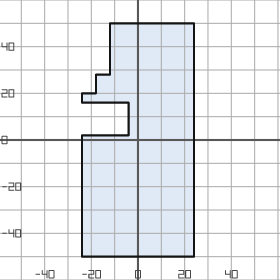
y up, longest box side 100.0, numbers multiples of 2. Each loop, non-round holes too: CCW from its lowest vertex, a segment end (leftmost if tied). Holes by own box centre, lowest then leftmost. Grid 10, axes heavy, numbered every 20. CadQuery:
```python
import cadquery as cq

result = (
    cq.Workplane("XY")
    .moveTo(-24.0, -50.0)
    .lineTo(24.0, -50.0)
    .lineTo(24.0, 50.0)
    .lineTo(-12.0, 50.0)
    .lineTo(-12.0, 28.0)
    .lineTo(-18.0, 28.0)
    .lineTo(-18.0, 20.0)
    .lineTo(-24.0, 20.0)
    .lineTo(-24.0, 16.0)
    .lineTo(-4.0, 16.0)
    .lineTo(-4.0, 2.0)
    .lineTo(-24.0, 2.0)
    .close()
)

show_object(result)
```